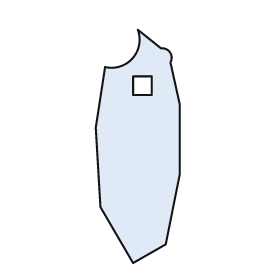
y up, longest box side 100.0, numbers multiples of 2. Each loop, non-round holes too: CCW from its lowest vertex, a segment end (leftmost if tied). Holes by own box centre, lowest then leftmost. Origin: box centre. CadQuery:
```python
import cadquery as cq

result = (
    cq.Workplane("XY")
    .moveTo(-2.0, -50.0)
    .lineTo(12.0, -42.0)
    .lineTo(18.0, -12.0)
    .lineTo(18.0, 18.0)
    .lineTo(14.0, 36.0)
    .threePointArc((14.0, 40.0), (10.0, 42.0))
    .lineTo(0.0, 50.0)
    .threePointArc((-2.0, 38.0), (-14.0, 34.0))
    .lineTo(-18.0, 8.0)
    .lineTo(-16.0, -26.0)
    .close()
    .moveTo(-2.0, 22.0)
    .lineTo(6.0, 22.0)
    .lineTo(6.0, 30.0)
    .lineTo(-2.0, 30.0)
    .close()
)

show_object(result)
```